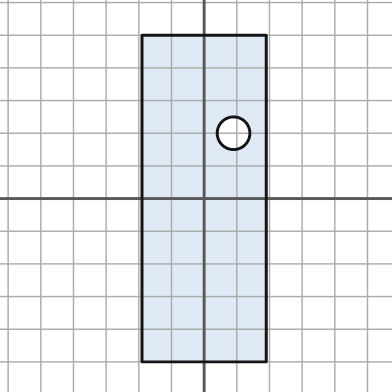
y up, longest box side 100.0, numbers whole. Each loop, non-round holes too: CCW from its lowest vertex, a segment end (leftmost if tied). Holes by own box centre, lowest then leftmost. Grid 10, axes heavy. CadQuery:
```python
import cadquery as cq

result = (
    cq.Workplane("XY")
    .moveTo(-19.0, -50.0)
    .lineTo(19.0, -50.0)
    .lineTo(19.0, 50.0)
    .lineTo(-19.0, 50.0)
    .close()
    .moveTo(9.0, 20.0)
    .circle(5.0)
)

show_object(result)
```